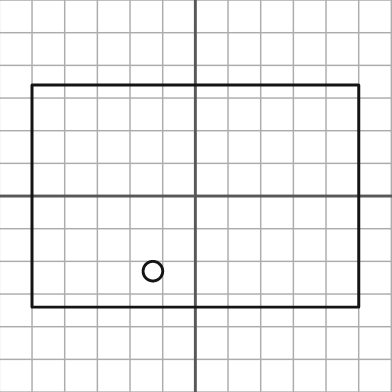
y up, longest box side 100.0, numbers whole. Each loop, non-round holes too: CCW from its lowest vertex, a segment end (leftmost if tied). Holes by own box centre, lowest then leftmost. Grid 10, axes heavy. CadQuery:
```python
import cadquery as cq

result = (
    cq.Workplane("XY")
    .moveTo(-50.0, -34.0)
    .lineTo(50.0, -34.0)
    .lineTo(50.0, 34.0)
    .lineTo(-50.0, 34.0)
    .close()
    .moveTo(-13.0, -23.0)
    .circle(3.0)
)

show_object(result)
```